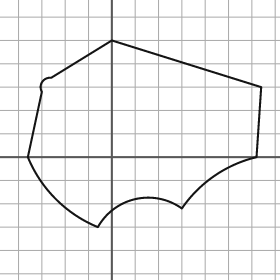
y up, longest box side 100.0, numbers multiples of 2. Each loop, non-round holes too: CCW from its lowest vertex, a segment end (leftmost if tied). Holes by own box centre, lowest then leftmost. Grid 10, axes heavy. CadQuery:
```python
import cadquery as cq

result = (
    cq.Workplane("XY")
    .moveTo(-6.0, -30.0)
    .threePointArc((10.0, -18.0), (30.0, -22.0))
    .threePointArc((44.0, -8.0), (62.0, 0.0))
    .lineTo(64.0, 30.0)
    .lineTo(0.0, 50.0)
    .lineTo(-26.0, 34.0)
    .threePointArc((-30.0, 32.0), (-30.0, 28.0))
    .lineTo(-36.0, 0.0)
    .threePointArc((-24.0, -18.0), (-6.0, -30.0))
    .close()
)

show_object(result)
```